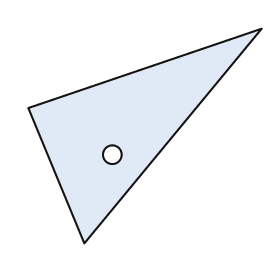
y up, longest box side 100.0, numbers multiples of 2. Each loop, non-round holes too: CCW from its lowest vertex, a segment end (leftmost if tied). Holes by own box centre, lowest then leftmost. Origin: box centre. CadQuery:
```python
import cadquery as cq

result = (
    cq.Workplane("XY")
    .moveTo(-26.0, -46.0)
    .lineTo(50.0, 46.0)
    .lineTo(-50.0, 12.0)
    .close()
    .moveTo(-14.0, -8.0)
    .circle(4.0)
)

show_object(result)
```